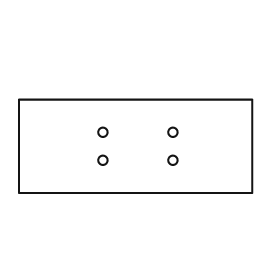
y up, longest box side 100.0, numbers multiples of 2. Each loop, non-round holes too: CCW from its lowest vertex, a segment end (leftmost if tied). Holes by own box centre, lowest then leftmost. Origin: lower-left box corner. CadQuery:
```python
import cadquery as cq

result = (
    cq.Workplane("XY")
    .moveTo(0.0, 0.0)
    .lineTo(100.0, 0.0)
    .lineTo(100.0, 40.0)
    .lineTo(0.0, 40.0)
    .close()
    .moveTo(36.0, 14.0)
    .circle(2.0)
    .moveTo(66.0, 14.0)
    .circle(2.0)
    .moveTo(36.0, 26.0)
    .circle(2.0)
    .moveTo(66.0, 26.0)
    .circle(2.0)
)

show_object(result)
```